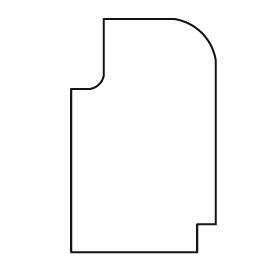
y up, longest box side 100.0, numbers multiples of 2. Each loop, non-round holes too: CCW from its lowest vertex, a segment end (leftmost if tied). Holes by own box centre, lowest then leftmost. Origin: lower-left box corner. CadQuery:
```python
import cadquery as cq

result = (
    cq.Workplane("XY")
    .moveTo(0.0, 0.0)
    .lineTo(54.0, 0.0)
    .lineTo(54.0, 12.0)
    .lineTo(62.0, 12.0)
    .lineTo(62.0, 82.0)
    .threePointArc((56.0, 94.0), (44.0, 100.0))
    .lineTo(14.0, 100.0)
    .lineTo(14.0, 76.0)
    .threePointArc((12.0, 72.0), (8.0, 70.0))
    .lineTo(0.0, 70.0)
    .close()
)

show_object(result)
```